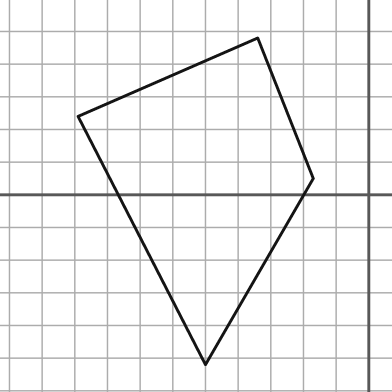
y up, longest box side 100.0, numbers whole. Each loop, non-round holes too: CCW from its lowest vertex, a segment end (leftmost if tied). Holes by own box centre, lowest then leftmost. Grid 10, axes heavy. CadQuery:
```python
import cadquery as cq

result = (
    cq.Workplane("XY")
    .moveTo(-50.0, -52.0)
    .lineTo(-17.0, 5.0)
    .lineTo(-34.0, 48.0)
    .lineTo(-89.0, 24.0)
    .close()
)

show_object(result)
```